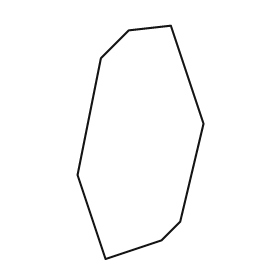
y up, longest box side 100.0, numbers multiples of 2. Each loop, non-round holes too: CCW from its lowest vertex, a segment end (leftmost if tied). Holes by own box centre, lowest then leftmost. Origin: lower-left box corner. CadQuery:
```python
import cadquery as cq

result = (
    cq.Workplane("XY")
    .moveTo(12.0, 0.0)
    .lineTo(36.0, 8.0)
    .lineTo(44.0, 16.0)
    .lineTo(54.0, 58.0)
    .lineTo(40.0, 100.0)
    .lineTo(22.0, 98.0)
    .lineTo(10.0, 86.0)
    .lineTo(0.0, 36.0)
    .close()
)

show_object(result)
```